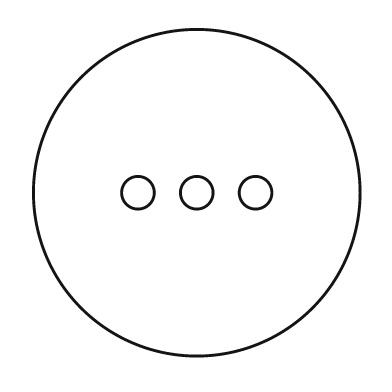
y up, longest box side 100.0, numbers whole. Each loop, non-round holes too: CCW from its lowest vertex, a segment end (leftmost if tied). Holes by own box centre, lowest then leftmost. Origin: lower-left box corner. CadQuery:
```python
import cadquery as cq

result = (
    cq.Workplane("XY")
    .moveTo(50.0, 50.0)
    .circle(50.0)
    .moveTo(32.0, 50.0)
    .circle(5.0)
    .moveTo(50.0, 50.0)
    .circle(5.0)
    .moveTo(68.0, 50.0)
    .circle(5.0)
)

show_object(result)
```